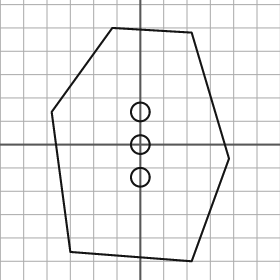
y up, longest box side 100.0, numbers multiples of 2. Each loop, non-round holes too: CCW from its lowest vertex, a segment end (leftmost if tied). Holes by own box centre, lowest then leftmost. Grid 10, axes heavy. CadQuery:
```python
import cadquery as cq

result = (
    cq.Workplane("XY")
    .moveTo(22.0, -50.0)
    .lineTo(38.0, -6.0)
    .lineTo(22.0, 48.0)
    .lineTo(-12.0, 50.0)
    .lineTo(-38.0, 14.0)
    .lineTo(-30.0, -46.0)
    .close()
    .moveTo(0.0, -14.0)
    .circle(4.0)
    .moveTo(0.0, 0.0)
    .circle(4.0)
    .moveTo(0.0, 14.0)
    .circle(4.0)
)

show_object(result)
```